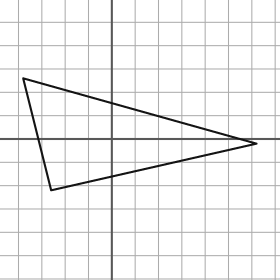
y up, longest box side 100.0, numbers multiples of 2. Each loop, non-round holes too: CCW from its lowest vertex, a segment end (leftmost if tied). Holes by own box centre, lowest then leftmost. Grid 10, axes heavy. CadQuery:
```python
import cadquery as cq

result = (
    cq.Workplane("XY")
    .moveTo(-26.0, -22.0)
    .lineTo(62.0, -2.0)
    .lineTo(-38.0, 26.0)
    .close()
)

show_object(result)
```